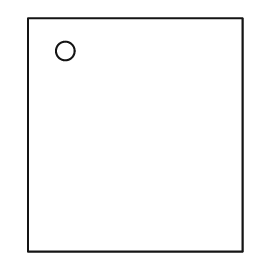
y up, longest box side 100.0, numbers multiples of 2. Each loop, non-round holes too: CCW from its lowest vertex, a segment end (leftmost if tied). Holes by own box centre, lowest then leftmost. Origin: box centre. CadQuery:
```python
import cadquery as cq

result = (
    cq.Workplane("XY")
    .moveTo(-46.0, -50.0)
    .lineTo(46.0, -50.0)
    .lineTo(46.0, 50.0)
    .lineTo(-46.0, 50.0)
    .close()
    .moveTo(-30.0, 36.0)
    .circle(4.0)
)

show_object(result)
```